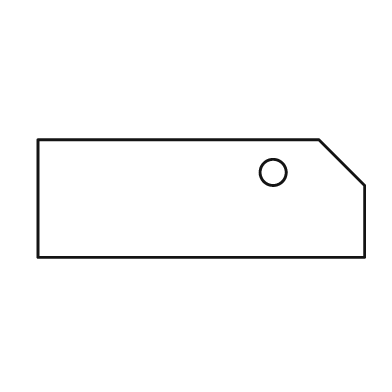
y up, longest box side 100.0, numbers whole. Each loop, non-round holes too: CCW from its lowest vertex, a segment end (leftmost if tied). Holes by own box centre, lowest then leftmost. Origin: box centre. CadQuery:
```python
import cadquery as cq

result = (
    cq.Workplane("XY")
    .moveTo(-50.0, -18.0)
    .lineTo(50.0, -18.0)
    .lineTo(50.0, 4.0)
    .lineTo(36.0, 18.0)
    .lineTo(-50.0, 18.0)
    .close()
    .moveTo(22.0, 8.0)
    .circle(4.0)
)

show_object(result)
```